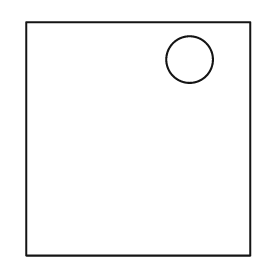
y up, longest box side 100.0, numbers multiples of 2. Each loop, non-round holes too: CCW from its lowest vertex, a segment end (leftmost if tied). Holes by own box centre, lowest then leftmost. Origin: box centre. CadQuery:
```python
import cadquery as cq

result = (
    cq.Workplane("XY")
    .moveTo(-48.0, -50.0)
    .lineTo(48.0, -50.0)
    .lineTo(48.0, 50.0)
    .lineTo(-48.0, 50.0)
    .close()
    .moveTo(22.0, 34.0)
    .circle(10.0)
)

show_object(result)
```